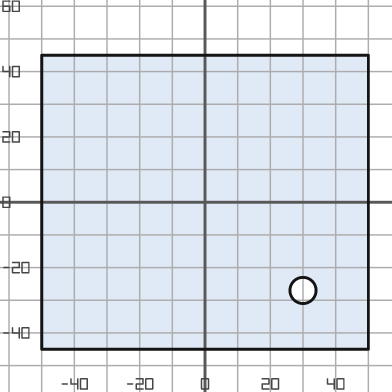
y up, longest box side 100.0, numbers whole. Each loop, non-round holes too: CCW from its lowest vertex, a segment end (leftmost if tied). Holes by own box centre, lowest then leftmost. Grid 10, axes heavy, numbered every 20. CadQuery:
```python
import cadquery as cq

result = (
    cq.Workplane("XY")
    .moveTo(-50.0, -45.0)
    .lineTo(50.0, -45.0)
    .lineTo(50.0, 45.0)
    .lineTo(-50.0, 45.0)
    .close()
    .moveTo(30.0, -27.0)
    .circle(4.0)
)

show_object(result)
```